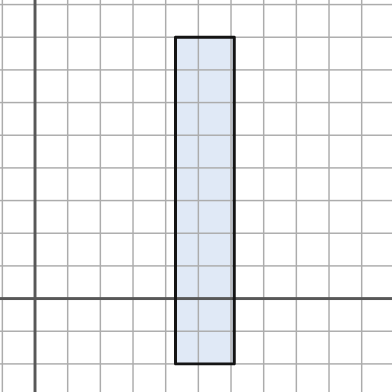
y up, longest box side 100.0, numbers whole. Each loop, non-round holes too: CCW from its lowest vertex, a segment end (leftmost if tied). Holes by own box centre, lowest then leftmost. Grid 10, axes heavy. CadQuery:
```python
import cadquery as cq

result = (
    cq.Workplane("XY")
    .moveTo(43.0, -20.0)
    .lineTo(61.0, -20.0)
    .lineTo(61.0, 80.0)
    .lineTo(43.0, 80.0)
    .close()
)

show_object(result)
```